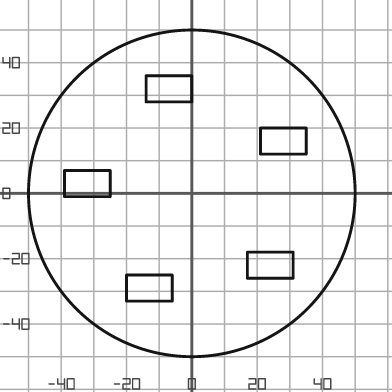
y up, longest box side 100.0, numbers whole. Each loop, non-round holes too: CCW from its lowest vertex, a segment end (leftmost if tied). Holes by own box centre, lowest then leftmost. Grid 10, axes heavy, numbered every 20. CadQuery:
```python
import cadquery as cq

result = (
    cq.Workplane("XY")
    .moveTo(0.0, 0.0)
    .circle(50.0)
    .moveTo(-20.0, -33.0)
    .lineTo(-6.0, -33.0)
    .lineTo(-6.0, -25.0)
    .lineTo(-20.0, -25.0)
    .close()
    .moveTo(17.0, -26.0)
    .lineTo(31.0, -26.0)
    .lineTo(31.0, -18.0)
    .lineTo(17.0, -18.0)
    .close()
    .moveTo(-39.0, -1.0)
    .lineTo(-25.0, -1.0)
    .lineTo(-25.0, 7.0)
    .lineTo(-39.0, 7.0)
    .close()
    .moveTo(21.0, 12.0)
    .lineTo(35.0, 12.0)
    .lineTo(35.0, 20.0)
    .lineTo(21.0, 20.0)
    .close()
    .moveTo(-14.0, 28.0)
    .lineTo(0.0, 28.0)
    .lineTo(0.0, 36.0)
    .lineTo(-14.0, 36.0)
    .close()
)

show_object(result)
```